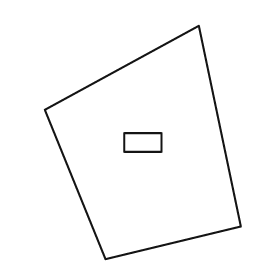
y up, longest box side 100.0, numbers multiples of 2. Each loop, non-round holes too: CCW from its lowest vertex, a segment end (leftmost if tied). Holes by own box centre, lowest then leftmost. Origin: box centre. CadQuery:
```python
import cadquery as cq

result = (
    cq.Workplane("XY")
    .moveTo(-16.0, -50.0)
    .lineTo(42.0, -36.0)
    .lineTo(24.0, 50.0)
    .lineTo(-42.0, 14.0)
    .close()
    .moveTo(-8.0, -4.0)
    .lineTo(8.0, -4.0)
    .lineTo(8.0, 4.0)
    .lineTo(-8.0, 4.0)
    .close()
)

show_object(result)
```